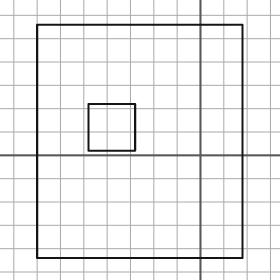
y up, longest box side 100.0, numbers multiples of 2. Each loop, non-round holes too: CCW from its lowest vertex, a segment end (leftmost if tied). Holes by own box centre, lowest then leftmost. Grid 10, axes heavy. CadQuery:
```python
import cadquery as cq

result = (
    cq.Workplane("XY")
    .moveTo(-70.0, -44.0)
    .lineTo(18.0, -44.0)
    .lineTo(18.0, 56.0)
    .lineTo(-70.0, 56.0)
    .close()
    .moveTo(-48.0, 2.0)
    .lineTo(-28.0, 2.0)
    .lineTo(-28.0, 22.0)
    .lineTo(-48.0, 22.0)
    .close()
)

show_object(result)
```